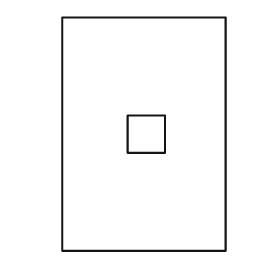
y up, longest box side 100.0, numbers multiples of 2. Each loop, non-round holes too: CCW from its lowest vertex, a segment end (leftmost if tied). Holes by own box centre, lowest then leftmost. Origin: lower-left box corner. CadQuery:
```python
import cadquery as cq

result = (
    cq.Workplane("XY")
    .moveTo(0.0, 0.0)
    .lineTo(70.0, 0.0)
    .lineTo(70.0, 100.0)
    .lineTo(0.0, 100.0)
    .close()
    .moveTo(28.0, 42.0)
    .lineTo(44.0, 42.0)
    .lineTo(44.0, 58.0)
    .lineTo(28.0, 58.0)
    .close()
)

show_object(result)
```